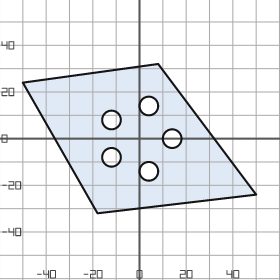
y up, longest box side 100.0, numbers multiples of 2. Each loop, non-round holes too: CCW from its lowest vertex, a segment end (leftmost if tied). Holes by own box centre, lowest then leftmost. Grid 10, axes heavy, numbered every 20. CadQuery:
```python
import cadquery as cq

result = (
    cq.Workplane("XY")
    .moveTo(-18.0, -32.0)
    .lineTo(50.0, -24.0)
    .lineTo(8.0, 32.0)
    .lineTo(-50.0, 24.0)
    .close()
    .moveTo(4.0, -14.0)
    .circle(4.0)
    .moveTo(-12.0, -8.0)
    .circle(4.0)
    .moveTo(14.0, 0.0)
    .circle(4.0)
    .moveTo(-12.0, 8.0)
    .circle(4.0)
    .moveTo(4.0, 14.0)
    .circle(4.0)
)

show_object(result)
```